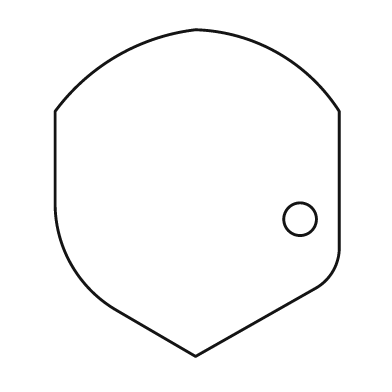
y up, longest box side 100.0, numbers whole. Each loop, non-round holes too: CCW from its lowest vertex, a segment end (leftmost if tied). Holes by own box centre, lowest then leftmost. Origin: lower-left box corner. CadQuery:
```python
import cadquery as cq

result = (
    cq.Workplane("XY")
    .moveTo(43.0, 0.0)
    .lineTo(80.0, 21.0)
    .threePointArc((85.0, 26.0), (87.0, 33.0))
    .lineTo(87.0, 75.0)
    .threePointArc((68.0, 93.0), (43.0, 100.0))
    .threePointArc((19.0, 92.0), (0.0, 75.0))
    .lineTo(0.0, 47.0)
    .threePointArc((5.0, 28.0), (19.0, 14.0))
    .close()
    .moveTo(75.0, 42.0)
    .circle(5.0)
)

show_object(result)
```